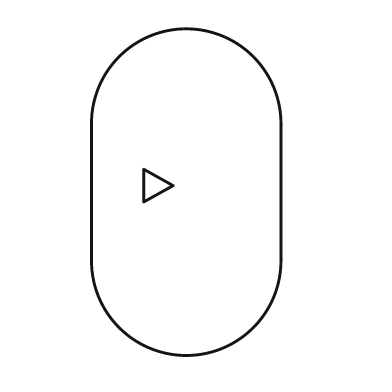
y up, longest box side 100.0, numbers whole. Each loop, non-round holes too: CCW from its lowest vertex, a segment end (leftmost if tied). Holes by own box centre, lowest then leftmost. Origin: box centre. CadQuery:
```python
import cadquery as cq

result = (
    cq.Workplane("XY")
    .moveTo(-29.0, -21.0)
    .threePointArc((0.0, -50.0), (29.0, -21.0))
    .lineTo(29.0, 21.0)
    .threePointArc((0.0, 50.0), (-29.0, 21.0))
    .close()
    .moveTo(-13.0, -3.0)
    .lineTo(-4.0, 2.0)
    .lineTo(-13.0, 7.0)
    .close()
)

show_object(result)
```